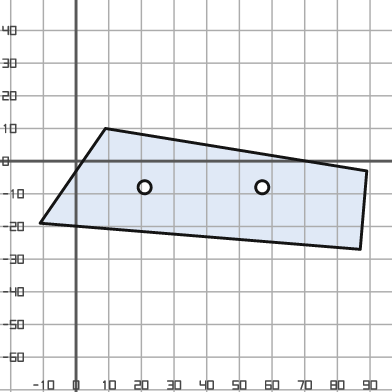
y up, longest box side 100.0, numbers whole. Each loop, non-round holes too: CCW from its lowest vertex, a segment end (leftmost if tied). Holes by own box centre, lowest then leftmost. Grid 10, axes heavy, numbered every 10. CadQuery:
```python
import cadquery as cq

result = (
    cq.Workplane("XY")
    .moveTo(87.0, -27.0)
    .lineTo(89.0, -3.0)
    .lineTo(9.0, 10.0)
    .lineTo(-11.0, -19.0)
    .close()
    .moveTo(21.0, -8.0)
    .circle(2.0)
    .moveTo(57.0, -8.0)
    .circle(2.0)
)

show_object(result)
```